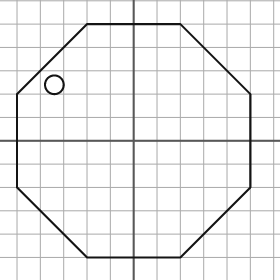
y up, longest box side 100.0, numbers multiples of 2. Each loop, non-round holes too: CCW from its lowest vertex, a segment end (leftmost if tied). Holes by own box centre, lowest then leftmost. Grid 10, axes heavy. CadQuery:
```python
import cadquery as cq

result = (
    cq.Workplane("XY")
    .moveTo(-20.0, -50.0)
    .lineTo(20.0, -50.0)
    .lineTo(50.0, -20.0)
    .lineTo(50.0, 20.0)
    .lineTo(20.0, 50.0)
    .lineTo(-20.0, 50.0)
    .lineTo(-50.0, 20.0)
    .lineTo(-50.0, -20.0)
    .close()
    .moveTo(-34.0, 24.0)
    .circle(4.0)
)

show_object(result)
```